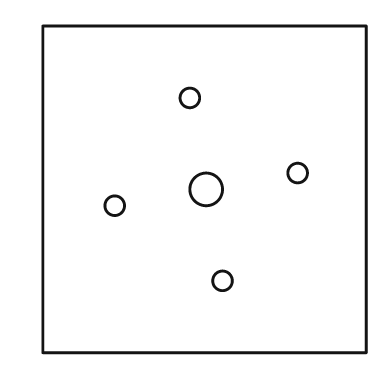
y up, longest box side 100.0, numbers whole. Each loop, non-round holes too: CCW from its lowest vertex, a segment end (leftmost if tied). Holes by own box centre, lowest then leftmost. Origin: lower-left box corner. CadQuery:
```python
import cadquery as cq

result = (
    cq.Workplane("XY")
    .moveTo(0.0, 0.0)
    .lineTo(99.0, 0.0)
    .lineTo(99.0, 100.0)
    .lineTo(0.0, 100.0)
    .close()
    .moveTo(55.0, 22.0)
    .circle(3.0)
    .moveTo(22.0, 45.0)
    .circle(3.0)
    .moveTo(50.0, 50.0)
    .circle(5.0)
    .moveTo(78.0, 55.0)
    .circle(3.0)
    .moveTo(45.0, 78.0)
    .circle(3.0)
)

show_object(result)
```